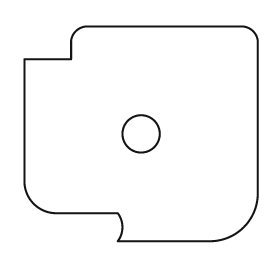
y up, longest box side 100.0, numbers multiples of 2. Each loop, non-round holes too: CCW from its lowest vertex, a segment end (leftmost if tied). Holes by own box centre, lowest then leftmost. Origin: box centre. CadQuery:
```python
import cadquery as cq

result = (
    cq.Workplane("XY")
    .moveTo(-10.0, -46.0)
    .lineTo(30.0, -46.0)
    .threePointArc((44.0, -40.0), (50.0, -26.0))
    .lineTo(50.0, 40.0)
    .threePointArc((48.0, 44.0), (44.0, 46.0))
    .lineTo(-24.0, 46.0)
    .threePointArc((-28.0, 44.0), (-30.0, 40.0))
    .lineTo(-30.0, 32.0)
    .lineTo(-50.0, 32.0)
    .lineTo(-50.0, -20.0)
    .threePointArc((-46.0, -30.0), (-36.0, -34.0))
    .lineTo(-10.0, -34.0)
    .threePointArc((-8.0, -40.0), (-10.0, -46.0))
    .close()
    .moveTo(0.0, 0.0)
    .circle(8.0)
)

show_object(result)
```